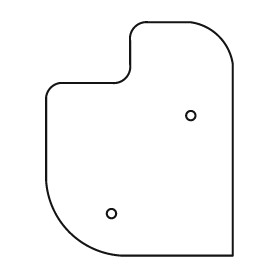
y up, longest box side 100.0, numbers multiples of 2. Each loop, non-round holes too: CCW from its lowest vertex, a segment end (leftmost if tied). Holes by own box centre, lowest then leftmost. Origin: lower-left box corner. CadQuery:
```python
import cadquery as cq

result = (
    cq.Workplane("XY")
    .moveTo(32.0, 0.0)
    .lineTo(80.0, 0.0)
    .lineTo(80.0, 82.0)
    .threePointArc((74.0, 94.0), (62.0, 100.0))
    .lineTo(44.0, 100.0)
    .threePointArc((38.0, 98.0), (36.0, 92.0))
    .lineTo(36.0, 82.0)
    .threePointArc((34.0, 76.0), (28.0, 74.0))
    .lineTo(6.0, 74.0)
    .threePointArc((2.0, 72.0), (0.0, 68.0))
    .lineTo(0.0, 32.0)
    .threePointArc((10.0, 10.0), (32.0, 0.0))
    .close()
    .moveTo(28.0, 18.0)
    .circle(2.0)
    .moveTo(62.0, 60.0)
    .circle(2.0)
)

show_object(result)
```